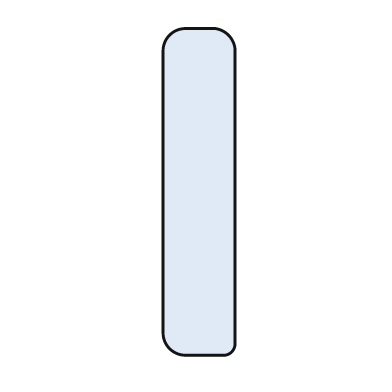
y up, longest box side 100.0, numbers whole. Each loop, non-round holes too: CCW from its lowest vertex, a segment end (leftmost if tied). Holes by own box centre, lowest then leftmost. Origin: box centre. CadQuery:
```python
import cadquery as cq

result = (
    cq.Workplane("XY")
    .moveTo(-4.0, -50.0)
    .lineTo(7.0, -50.0)
    .threePointArc((10.0, -49.0), (11.0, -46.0))
    .lineTo(11.0, 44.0)
    .threePointArc((9.0, 48.0), (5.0, 50.0))
    .lineTo(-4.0, 50.0)
    .threePointArc((-9.0, 48.0), (-11.0, 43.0))
    .lineTo(-11.0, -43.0)
    .threePointArc((-9.0, -48.0), (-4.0, -50.0))
    .close()
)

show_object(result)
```